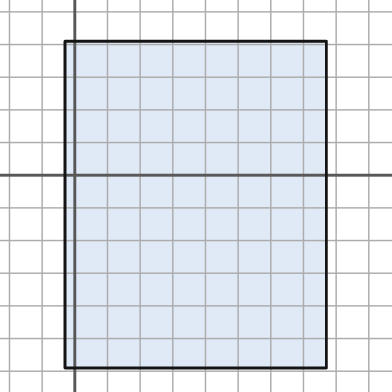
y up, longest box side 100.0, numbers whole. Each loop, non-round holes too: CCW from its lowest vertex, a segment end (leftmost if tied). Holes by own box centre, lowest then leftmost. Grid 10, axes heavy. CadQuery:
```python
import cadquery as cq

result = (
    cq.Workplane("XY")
    .moveTo(-3.0, -59.0)
    .lineTo(77.0, -59.0)
    .lineTo(77.0, 41.0)
    .lineTo(-3.0, 41.0)
    .close()
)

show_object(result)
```